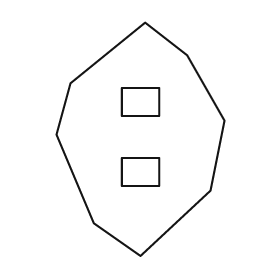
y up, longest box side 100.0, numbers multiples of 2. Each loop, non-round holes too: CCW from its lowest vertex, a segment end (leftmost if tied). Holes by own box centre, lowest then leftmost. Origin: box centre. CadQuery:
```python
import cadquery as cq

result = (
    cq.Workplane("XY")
    .moveTo(0.0, -50.0)
    .lineTo(30.0, -22.0)
    .lineTo(36.0, 8.0)
    .lineTo(20.0, 36.0)
    .lineTo(2.0, 50.0)
    .lineTo(-30.0, 24.0)
    .lineTo(-36.0, 2.0)
    .lineTo(-20.0, -36.0)
    .close()
    .moveTo(-8.0, -20.0)
    .lineTo(8.0, -20.0)
    .lineTo(8.0, -8.0)
    .lineTo(-8.0, -8.0)
    .close()
    .moveTo(-8.0, 10.0)
    .lineTo(8.0, 10.0)
    .lineTo(8.0, 22.0)
    .lineTo(-8.0, 22.0)
    .close()
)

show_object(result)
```